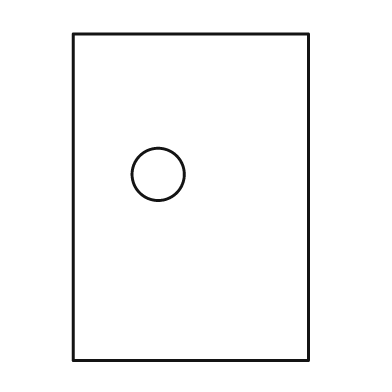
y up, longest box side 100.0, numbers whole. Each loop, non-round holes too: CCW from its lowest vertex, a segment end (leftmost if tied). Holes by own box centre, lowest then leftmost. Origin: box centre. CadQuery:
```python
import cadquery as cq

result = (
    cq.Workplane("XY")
    .moveTo(-36.0, -50.0)
    .lineTo(36.0, -50.0)
    .lineTo(36.0, 50.0)
    .lineTo(-36.0, 50.0)
    .close()
    .moveTo(-10.0, 7.0)
    .circle(8.0)
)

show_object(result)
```